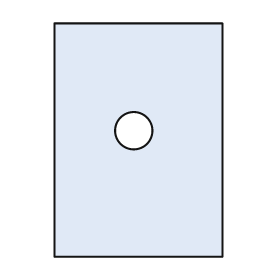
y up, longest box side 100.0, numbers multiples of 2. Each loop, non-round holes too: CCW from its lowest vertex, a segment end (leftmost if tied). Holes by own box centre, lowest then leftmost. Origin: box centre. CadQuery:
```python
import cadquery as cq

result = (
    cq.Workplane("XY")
    .moveTo(-36.0, -50.0)
    .lineTo(36.0, -50.0)
    .lineTo(36.0, 50.0)
    .lineTo(-36.0, 50.0)
    .close()
    .moveTo(-2.0, 4.0)
    .circle(8.0)
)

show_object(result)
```